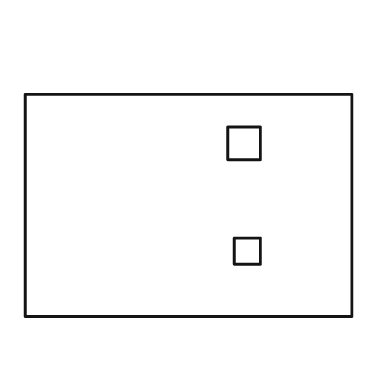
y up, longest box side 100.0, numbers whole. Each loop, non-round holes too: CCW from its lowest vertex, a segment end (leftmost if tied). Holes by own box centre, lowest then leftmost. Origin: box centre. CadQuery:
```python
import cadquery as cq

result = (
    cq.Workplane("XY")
    .moveTo(-50.0, -34.0)
    .lineTo(50.0, -34.0)
    .lineTo(50.0, 34.0)
    .lineTo(-50.0, 34.0)
    .close()
    .moveTo(14.0, -18.0)
    .lineTo(22.0, -18.0)
    .lineTo(22.0, -10.0)
    .lineTo(14.0, -10.0)
    .close()
    .moveTo(12.0, 14.0)
    .lineTo(22.0, 14.0)
    .lineTo(22.0, 24.0)
    .lineTo(12.0, 24.0)
    .close()
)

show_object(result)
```